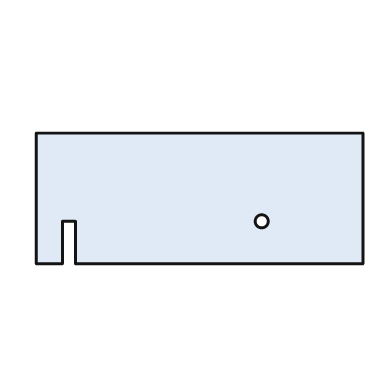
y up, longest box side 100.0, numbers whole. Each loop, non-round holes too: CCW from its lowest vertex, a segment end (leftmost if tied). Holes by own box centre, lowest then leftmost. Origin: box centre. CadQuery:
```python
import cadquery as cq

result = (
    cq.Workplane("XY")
    .moveTo(-50.0, -20.0)
    .lineTo(-42.0, -20.0)
    .lineTo(-42.0, -7.0)
    .lineTo(-38.0, -7.0)
    .lineTo(-38.0, -20.0)
    .lineTo(50.0, -20.0)
    .lineTo(50.0, 20.0)
    .lineTo(-50.0, 20.0)
    .close()
    .moveTo(19.0, -7.0)
    .circle(2.0)
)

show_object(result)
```